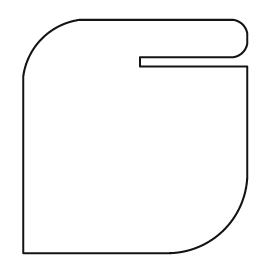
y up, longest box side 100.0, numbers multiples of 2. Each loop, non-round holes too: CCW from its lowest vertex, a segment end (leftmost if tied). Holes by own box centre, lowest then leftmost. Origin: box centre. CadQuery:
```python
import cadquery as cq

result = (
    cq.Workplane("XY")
    .moveTo(-48.0, -50.0)
    .lineTo(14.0, -50.0)
    .threePointArc((38.0, -40.0), (48.0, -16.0))
    .lineTo(48.0, 30.0)
    .lineTo(2.0, 30.0)
    .lineTo(2.0, 34.0)
    .lineTo(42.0, 34.0)
    .threePointArc((46.0, 36.0), (48.0, 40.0))
    .lineTo(48.0, 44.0)
    .threePointArc((46.0, 48.0), (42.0, 50.0))
    .lineTo(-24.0, 50.0)
    .threePointArc((-40.0, 42.0), (-48.0, 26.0))
    .close()
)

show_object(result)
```